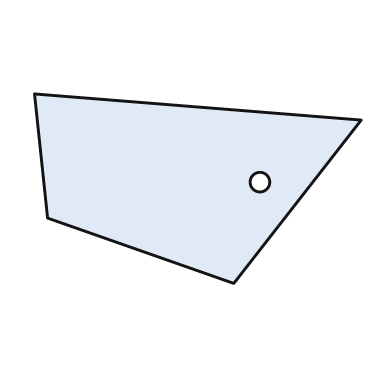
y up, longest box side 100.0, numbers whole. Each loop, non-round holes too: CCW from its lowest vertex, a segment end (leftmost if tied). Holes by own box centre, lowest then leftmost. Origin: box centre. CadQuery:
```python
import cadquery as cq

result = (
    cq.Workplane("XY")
    .moveTo(11.0, -29.0)
    .lineTo(50.0, 21.0)
    .lineTo(-50.0, 29.0)
    .lineTo(-46.0, -9.0)
    .close()
    .moveTo(19.0, 2.0)
    .circle(3.0)
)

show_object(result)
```